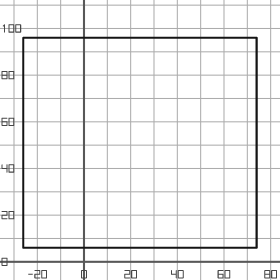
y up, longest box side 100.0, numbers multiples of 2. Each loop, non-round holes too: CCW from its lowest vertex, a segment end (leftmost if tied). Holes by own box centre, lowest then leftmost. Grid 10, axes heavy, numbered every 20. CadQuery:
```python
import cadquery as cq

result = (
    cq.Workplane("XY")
    .moveTo(-26.0, 6.0)
    .lineTo(74.0, 6.0)
    .lineTo(74.0, 96.0)
    .lineTo(-26.0, 96.0)
    .close()
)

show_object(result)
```